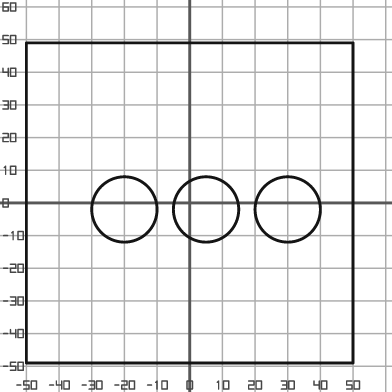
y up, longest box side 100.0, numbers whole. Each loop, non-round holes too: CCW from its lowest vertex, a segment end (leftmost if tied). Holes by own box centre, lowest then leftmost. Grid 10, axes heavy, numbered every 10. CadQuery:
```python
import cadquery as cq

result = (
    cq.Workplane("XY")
    .moveTo(-50.0, -49.0)
    .lineTo(50.0, -49.0)
    .lineTo(50.0, 49.0)
    .lineTo(-50.0, 49.0)
    .close()
    .moveTo(-20.0, -2.0)
    .circle(10.0)
    .moveTo(5.0, -2.0)
    .circle(10.0)
    .moveTo(30.0, -2.0)
    .circle(10.0)
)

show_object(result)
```